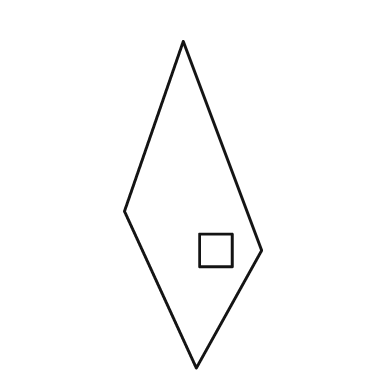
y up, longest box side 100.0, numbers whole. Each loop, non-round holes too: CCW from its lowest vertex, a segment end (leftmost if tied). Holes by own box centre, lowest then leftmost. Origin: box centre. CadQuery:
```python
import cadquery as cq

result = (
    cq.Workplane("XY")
    .moveTo(1.0, -50.0)
    .lineTo(21.0, -14.0)
    .lineTo(-3.0, 50.0)
    .lineTo(-21.0, -2.0)
    .close()
    .moveTo(2.0, -19.0)
    .lineTo(12.0, -19.0)
    .lineTo(12.0, -9.0)
    .lineTo(2.0, -9.0)
    .close()
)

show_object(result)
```